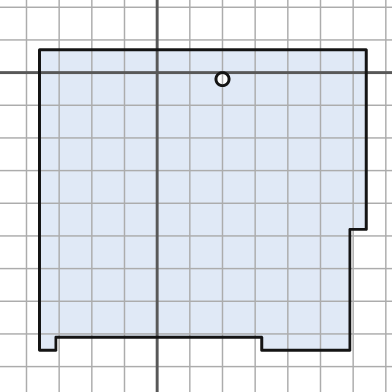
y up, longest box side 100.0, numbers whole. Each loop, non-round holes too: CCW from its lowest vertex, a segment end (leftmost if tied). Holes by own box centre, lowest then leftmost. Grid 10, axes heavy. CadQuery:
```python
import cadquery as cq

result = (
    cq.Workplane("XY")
    .moveTo(-36.0, -85.0)
    .lineTo(-31.0, -85.0)
    .lineTo(-31.0, -81.0)
    .lineTo(32.0, -81.0)
    .lineTo(32.0, -85.0)
    .lineTo(59.0, -85.0)
    .lineTo(59.0, -48.0)
    .lineTo(64.0, -48.0)
    .lineTo(64.0, 7.0)
    .lineTo(-36.0, 7.0)
    .close()
    .moveTo(20.0, -2.0)
    .circle(2.0)
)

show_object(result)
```